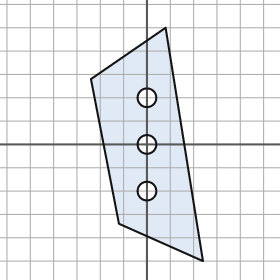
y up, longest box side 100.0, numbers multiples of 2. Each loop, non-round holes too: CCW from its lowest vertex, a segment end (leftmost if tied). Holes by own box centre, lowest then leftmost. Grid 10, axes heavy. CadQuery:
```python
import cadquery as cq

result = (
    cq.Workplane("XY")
    .moveTo(24.0, -50.0)
    .lineTo(8.0, 50.0)
    .lineTo(-24.0, 28.0)
    .lineTo(-12.0, -34.0)
    .close()
    .moveTo(0.0, -20.0)
    .circle(4.0)
    .moveTo(0.0, 0.0)
    .circle(4.0)
    .moveTo(0.0, 20.0)
    .circle(4.0)
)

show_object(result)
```